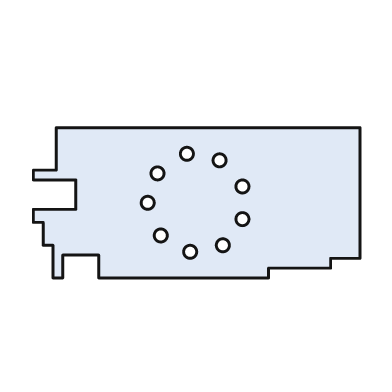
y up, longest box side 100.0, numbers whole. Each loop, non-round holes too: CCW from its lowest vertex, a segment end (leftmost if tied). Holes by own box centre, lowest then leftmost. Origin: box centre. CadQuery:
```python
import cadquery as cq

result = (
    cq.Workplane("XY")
    .moveTo(-44.0, -23.0)
    .lineTo(-41.0, -23.0)
    .lineTo(-41.0, -16.0)
    .lineTo(-30.0, -16.0)
    .lineTo(-30.0, -23.0)
    .lineTo(22.0, -23.0)
    .lineTo(22.0, -20.0)
    .lineTo(41.0, -20.0)
    .lineTo(41.0, -17.0)
    .lineTo(50.0, -17.0)
    .lineTo(50.0, 23.0)
    .lineTo(-43.0, 23.0)
    .lineTo(-43.0, 10.0)
    .lineTo(-50.0, 10.0)
    .lineTo(-50.0, 7.0)
    .lineTo(-37.0, 7.0)
    .lineTo(-37.0, -2.0)
    .lineTo(-50.0, -2.0)
    .lineTo(-50.0, -6.0)
    .lineTo(-47.0, -6.0)
    .lineTo(-47.0, -13.0)
    .lineTo(-44.0, -13.0)
    .close()
    .moveTo(-2.0, -15.0)
    .circle(2.0)
    .moveTo(8.0, -13.0)
    .circle(2.0)
    .moveTo(-11.0, -10.0)
    .circle(2.0)
    .moveTo(14.0, -5.0)
    .circle(2.0)
    .moveTo(-15.0, 0.0)
    .circle(2.0)
    .moveTo(14.0, 5.0)
    .circle(2.0)
    .moveTo(-12.0, 9.0)
    .circle(2.0)
    .moveTo(7.0, 13.0)
    .circle(2.0)
    .moveTo(-3.0, 15.0)
    .circle(2.0)
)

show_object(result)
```